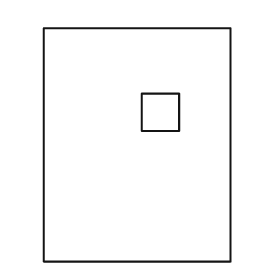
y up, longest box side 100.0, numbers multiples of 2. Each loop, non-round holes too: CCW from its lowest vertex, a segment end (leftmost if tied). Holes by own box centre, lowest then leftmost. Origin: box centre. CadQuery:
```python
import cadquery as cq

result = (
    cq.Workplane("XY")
    .moveTo(-40.0, -50.0)
    .lineTo(40.0, -50.0)
    .lineTo(40.0, 50.0)
    .lineTo(-40.0, 50.0)
    .close()
    .moveTo(2.0, 6.0)
    .lineTo(18.0, 6.0)
    .lineTo(18.0, 22.0)
    .lineTo(2.0, 22.0)
    .close()
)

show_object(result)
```